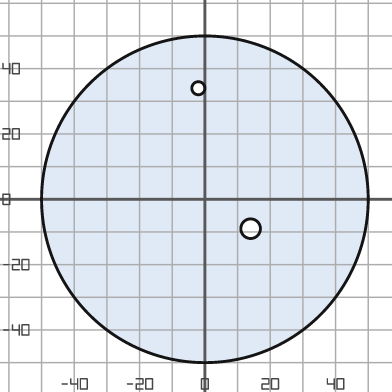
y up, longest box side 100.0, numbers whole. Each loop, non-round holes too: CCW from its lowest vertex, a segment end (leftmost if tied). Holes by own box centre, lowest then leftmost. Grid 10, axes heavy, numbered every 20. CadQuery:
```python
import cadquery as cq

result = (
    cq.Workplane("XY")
    .moveTo(0.0, 0.0)
    .circle(50.0)
    .moveTo(14.0, -9.0)
    .circle(3.0)
    .moveTo(-2.0, 34.0)
    .circle(2.0)
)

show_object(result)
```